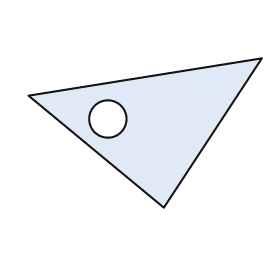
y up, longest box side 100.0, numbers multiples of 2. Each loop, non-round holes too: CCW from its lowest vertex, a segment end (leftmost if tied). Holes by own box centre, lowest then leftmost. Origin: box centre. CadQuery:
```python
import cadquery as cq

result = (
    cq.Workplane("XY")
    .moveTo(8.0, -32.0)
    .lineTo(50.0, 32.0)
    .lineTo(-50.0, 16.0)
    .close()
    .moveTo(-16.0, 6.0)
    .circle(8.0)
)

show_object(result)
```